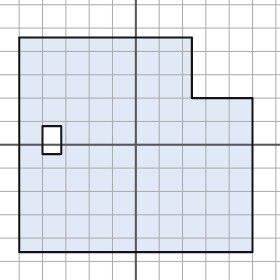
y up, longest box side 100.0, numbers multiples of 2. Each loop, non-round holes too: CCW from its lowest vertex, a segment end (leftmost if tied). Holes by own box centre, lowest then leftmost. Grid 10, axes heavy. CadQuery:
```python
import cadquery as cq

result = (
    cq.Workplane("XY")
    .moveTo(-50.0, -46.0)
    .lineTo(50.0, -46.0)
    .lineTo(50.0, 20.0)
    .lineTo(24.0, 20.0)
    .lineTo(24.0, 46.0)
    .lineTo(-50.0, 46.0)
    .close()
    .moveTo(-40.0, -4.0)
    .lineTo(-32.0, -4.0)
    .lineTo(-32.0, 8.0)
    .lineTo(-40.0, 8.0)
    .close()
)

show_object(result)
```